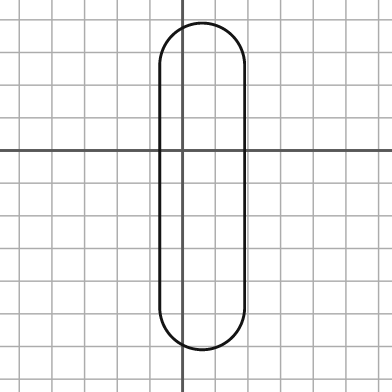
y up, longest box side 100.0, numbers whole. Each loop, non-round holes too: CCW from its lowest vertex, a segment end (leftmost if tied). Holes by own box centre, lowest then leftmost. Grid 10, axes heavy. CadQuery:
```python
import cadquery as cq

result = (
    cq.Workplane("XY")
    .moveTo(-7.0, -48.0)
    .threePointArc((6.0, -61.0), (19.0, -48.0))
    .lineTo(19.0, 26.0)
    .threePointArc((6.0, 39.0), (-7.0, 26.0))
    .close()
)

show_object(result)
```